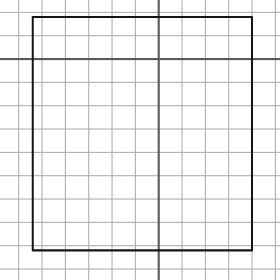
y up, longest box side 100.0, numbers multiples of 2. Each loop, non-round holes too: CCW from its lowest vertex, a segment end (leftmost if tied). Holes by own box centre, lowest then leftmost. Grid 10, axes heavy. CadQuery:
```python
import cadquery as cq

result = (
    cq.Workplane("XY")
    .moveTo(-54.0, -82.0)
    .lineTo(40.0, -82.0)
    .lineTo(40.0, 18.0)
    .lineTo(-54.0, 18.0)
    .close()
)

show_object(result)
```